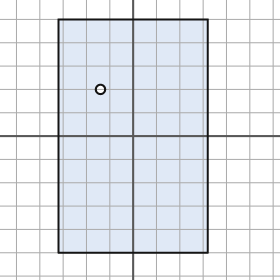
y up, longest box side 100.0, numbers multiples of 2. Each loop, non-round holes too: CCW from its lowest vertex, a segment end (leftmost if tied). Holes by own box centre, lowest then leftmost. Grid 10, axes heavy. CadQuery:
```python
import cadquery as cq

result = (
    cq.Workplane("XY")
    .moveTo(-32.0, -50.0)
    .lineTo(32.0, -50.0)
    .lineTo(32.0, 50.0)
    .lineTo(-32.0, 50.0)
    .close()
    .moveTo(-14.0, 20.0)
    .circle(2.0)
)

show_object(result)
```